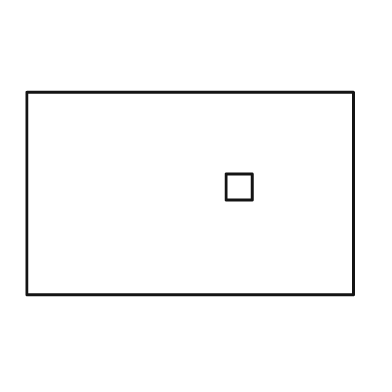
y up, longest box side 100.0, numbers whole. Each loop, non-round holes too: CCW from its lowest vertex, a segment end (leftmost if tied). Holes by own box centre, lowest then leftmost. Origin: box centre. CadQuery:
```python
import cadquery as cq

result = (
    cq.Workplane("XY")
    .moveTo(-50.0, -31.0)
    .lineTo(50.0, -31.0)
    .lineTo(50.0, 31.0)
    .lineTo(-50.0, 31.0)
    .close()
    .moveTo(11.0, -2.0)
    .lineTo(19.0, -2.0)
    .lineTo(19.0, 6.0)
    .lineTo(11.0, 6.0)
    .close()
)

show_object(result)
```